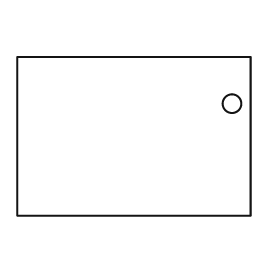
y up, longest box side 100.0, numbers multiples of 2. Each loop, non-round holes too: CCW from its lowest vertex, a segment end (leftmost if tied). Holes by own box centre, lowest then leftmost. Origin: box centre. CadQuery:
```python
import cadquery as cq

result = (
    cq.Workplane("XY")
    .moveTo(-50.0, -34.0)
    .lineTo(50.0, -34.0)
    .lineTo(50.0, 34.0)
    .lineTo(-50.0, 34.0)
    .close()
    .moveTo(42.0, 14.0)
    .circle(4.0)
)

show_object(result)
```